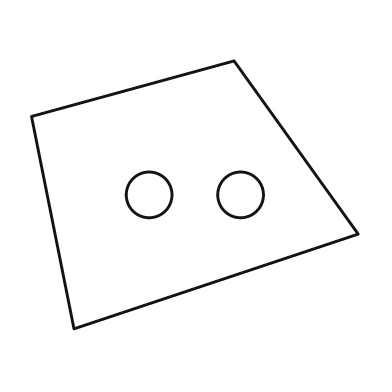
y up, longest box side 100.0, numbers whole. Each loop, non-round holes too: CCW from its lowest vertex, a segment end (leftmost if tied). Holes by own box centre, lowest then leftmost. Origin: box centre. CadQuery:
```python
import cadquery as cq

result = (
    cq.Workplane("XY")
    .moveTo(-37.0, -41.0)
    .lineTo(50.0, -12.0)
    .lineTo(12.0, 41.0)
    .lineTo(-50.0, 24.0)
    .close()
    .moveTo(-14.0, 0.0)
    .circle(7.0)
    .moveTo(14.0, 0.0)
    .circle(7.0)
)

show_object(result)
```